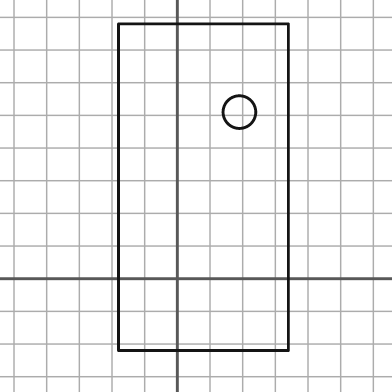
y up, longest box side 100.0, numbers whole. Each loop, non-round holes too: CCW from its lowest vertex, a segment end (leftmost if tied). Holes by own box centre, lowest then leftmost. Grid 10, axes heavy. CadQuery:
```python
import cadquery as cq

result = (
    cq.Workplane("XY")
    .moveTo(-18.0, -22.0)
    .lineTo(34.0, -22.0)
    .lineTo(34.0, 78.0)
    .lineTo(-18.0, 78.0)
    .close()
    .moveTo(19.0, 51.0)
    .circle(5.0)
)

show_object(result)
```